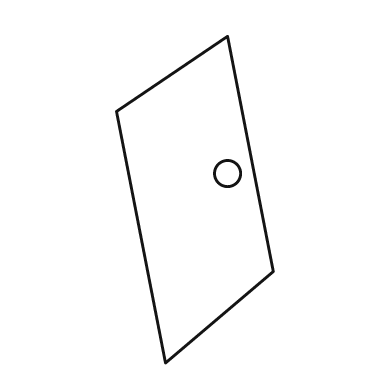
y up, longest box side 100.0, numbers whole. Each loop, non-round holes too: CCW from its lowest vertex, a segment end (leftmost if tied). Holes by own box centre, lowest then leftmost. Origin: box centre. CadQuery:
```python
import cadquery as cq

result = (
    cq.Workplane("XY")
    .moveTo(-9.0, -50.0)
    .lineTo(24.0, -22.0)
    .lineTo(10.0, 50.0)
    .lineTo(-24.0, 27.0)
    .close()
    .moveTo(10.0, 8.0)
    .circle(4.0)
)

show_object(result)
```